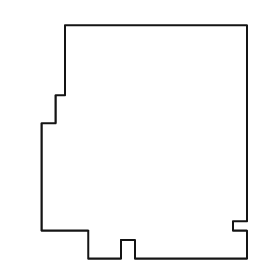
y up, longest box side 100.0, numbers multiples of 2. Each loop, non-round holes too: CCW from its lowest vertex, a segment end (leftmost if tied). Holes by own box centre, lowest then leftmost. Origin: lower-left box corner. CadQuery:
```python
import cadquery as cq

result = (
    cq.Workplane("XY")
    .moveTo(20.0, 0.0)
    .lineTo(34.0, 0.0)
    .lineTo(34.0, 8.0)
    .lineTo(40.0, 8.0)
    .lineTo(40.0, 0.0)
    .lineTo(88.0, 0.0)
    .lineTo(88.0, 12.0)
    .lineTo(82.0, 12.0)
    .lineTo(82.0, 16.0)
    .lineTo(88.0, 16.0)
    .lineTo(88.0, 100.0)
    .lineTo(10.0, 100.0)
    .lineTo(10.0, 70.0)
    .lineTo(6.0, 70.0)
    .lineTo(6.0, 58.0)
    .lineTo(0.0, 58.0)
    .lineTo(0.0, 12.0)
    .lineTo(20.0, 12.0)
    .close()
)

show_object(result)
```